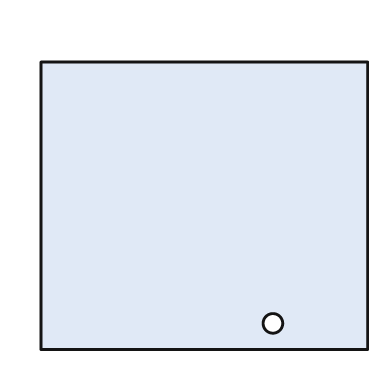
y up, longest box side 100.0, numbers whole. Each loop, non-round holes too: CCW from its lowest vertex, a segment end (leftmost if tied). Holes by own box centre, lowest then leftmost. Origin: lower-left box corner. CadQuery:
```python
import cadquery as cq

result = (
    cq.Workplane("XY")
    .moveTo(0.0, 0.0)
    .lineTo(100.0, 0.0)
    .lineTo(100.0, 88.0)
    .lineTo(0.0, 88.0)
    .close()
    .moveTo(71.0, 8.0)
    .circle(3.0)
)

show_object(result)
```